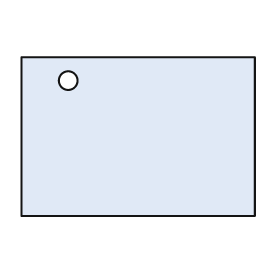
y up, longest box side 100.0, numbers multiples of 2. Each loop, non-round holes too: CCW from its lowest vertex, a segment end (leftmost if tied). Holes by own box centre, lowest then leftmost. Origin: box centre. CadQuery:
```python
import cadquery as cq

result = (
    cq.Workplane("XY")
    .moveTo(-50.0, -34.0)
    .lineTo(50.0, -34.0)
    .lineTo(50.0, 34.0)
    .lineTo(-50.0, 34.0)
    .close()
    .moveTo(-30.0, 24.0)
    .circle(4.0)
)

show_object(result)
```